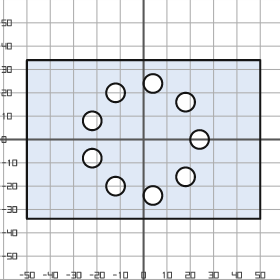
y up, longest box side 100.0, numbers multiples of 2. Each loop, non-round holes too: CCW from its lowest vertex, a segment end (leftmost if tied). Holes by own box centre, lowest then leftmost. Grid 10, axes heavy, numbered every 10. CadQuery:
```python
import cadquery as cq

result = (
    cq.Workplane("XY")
    .moveTo(-50.0, -34.0)
    .lineTo(50.0, -34.0)
    .lineTo(50.0, 34.0)
    .lineTo(-50.0, 34.0)
    .close()
    .moveTo(4.0, -24.0)
    .circle(4.0)
    .moveTo(-12.0, -20.0)
    .circle(4.0)
    .moveTo(18.0, -16.0)
    .circle(4.0)
    .moveTo(-22.0, -8.0)
    .circle(4.0)
    .moveTo(24.0, 0.0)
    .circle(4.0)
    .moveTo(-22.0, 8.0)
    .circle(4.0)
    .moveTo(18.0, 16.0)
    .circle(4.0)
    .moveTo(-12.0, 20.0)
    .circle(4.0)
    .moveTo(4.0, 24.0)
    .circle(4.0)
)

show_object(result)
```